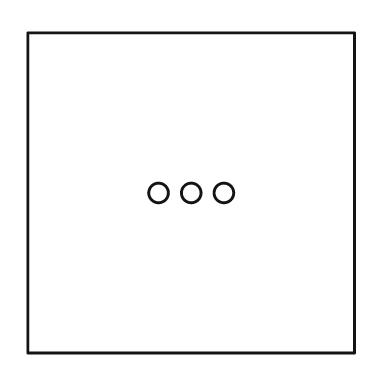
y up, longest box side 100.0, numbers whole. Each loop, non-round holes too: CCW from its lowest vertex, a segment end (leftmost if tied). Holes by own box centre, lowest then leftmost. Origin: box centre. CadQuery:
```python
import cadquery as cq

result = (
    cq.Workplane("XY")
    .moveTo(-50.0, -49.0)
    .lineTo(50.0, -49.0)
    .lineTo(50.0, 49.0)
    .lineTo(-50.0, 49.0)
    .close()
    .moveTo(-10.0, 0.0)
    .circle(3.0)
    .moveTo(0.0, 0.0)
    .circle(3.0)
    .moveTo(10.0, 0.0)
    .circle(3.0)
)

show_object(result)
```